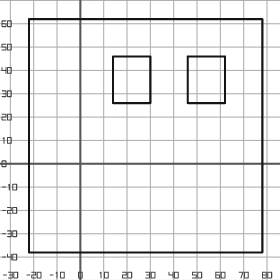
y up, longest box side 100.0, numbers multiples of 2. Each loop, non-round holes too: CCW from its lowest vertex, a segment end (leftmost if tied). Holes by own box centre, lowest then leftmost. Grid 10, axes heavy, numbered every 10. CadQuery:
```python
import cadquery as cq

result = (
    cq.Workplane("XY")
    .moveTo(-22.0, -38.0)
    .lineTo(78.0, -38.0)
    .lineTo(78.0, 62.0)
    .lineTo(-22.0, 62.0)
    .close()
    .moveTo(14.0, 26.0)
    .lineTo(30.0, 26.0)
    .lineTo(30.0, 46.0)
    .lineTo(14.0, 46.0)
    .close()
    .moveTo(46.0, 26.0)
    .lineTo(62.0, 26.0)
    .lineTo(62.0, 46.0)
    .lineTo(46.0, 46.0)
    .close()
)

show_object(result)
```